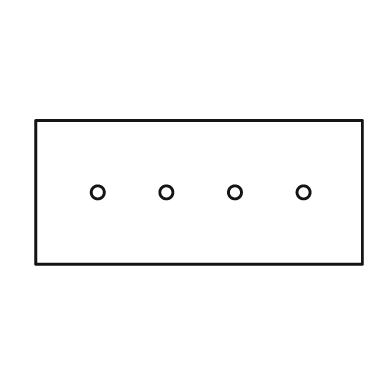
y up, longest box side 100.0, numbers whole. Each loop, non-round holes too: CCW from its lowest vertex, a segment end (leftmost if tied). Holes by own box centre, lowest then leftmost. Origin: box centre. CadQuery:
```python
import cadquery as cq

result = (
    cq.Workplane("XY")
    .moveTo(-50.0, -22.0)
    .lineTo(50.0, -22.0)
    .lineTo(50.0, 22.0)
    .lineTo(-50.0, 22.0)
    .close()
    .moveTo(-31.0, 0.0)
    .circle(2.0)
    .moveTo(-10.0, 0.0)
    .circle(2.0)
    .moveTo(11.0, 0.0)
    .circle(2.0)
    .moveTo(32.0, 0.0)
    .circle(2.0)
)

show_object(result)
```